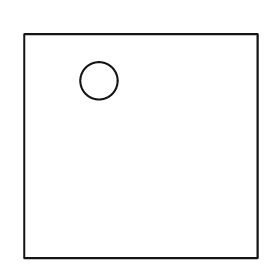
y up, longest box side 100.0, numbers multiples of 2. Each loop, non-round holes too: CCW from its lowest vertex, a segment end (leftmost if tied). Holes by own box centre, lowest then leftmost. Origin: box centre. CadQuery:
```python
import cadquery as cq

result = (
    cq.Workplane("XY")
    .moveTo(-50.0, -48.0)
    .lineTo(50.0, -48.0)
    .lineTo(50.0, 48.0)
    .lineTo(-50.0, 48.0)
    .close()
    .moveTo(-18.0, 28.0)
    .circle(8.0)
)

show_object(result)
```